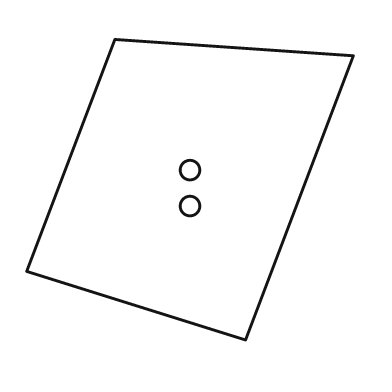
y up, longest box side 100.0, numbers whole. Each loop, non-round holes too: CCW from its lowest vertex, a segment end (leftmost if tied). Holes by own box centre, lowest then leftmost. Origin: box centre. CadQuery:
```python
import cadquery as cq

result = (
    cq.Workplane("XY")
    .moveTo(17.0, -46.0)
    .lineTo(50.0, 41.0)
    .lineTo(-23.0, 46.0)
    .lineTo(-50.0, -25.0)
    .close()
    .moveTo(0.0, -5.0)
    .circle(3.0)
    .moveTo(0.0, 6.0)
    .circle(3.0)
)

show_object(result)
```